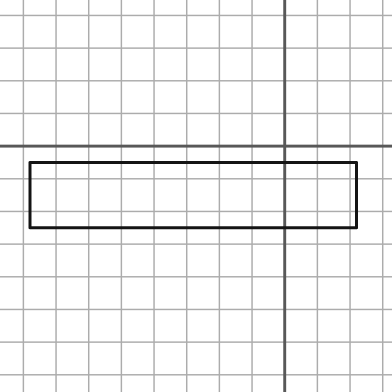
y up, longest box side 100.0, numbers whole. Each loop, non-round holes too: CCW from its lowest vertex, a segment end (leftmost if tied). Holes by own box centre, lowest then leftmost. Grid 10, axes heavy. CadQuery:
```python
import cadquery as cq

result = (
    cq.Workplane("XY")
    .moveTo(-78.0, -25.0)
    .lineTo(22.0, -25.0)
    .lineTo(22.0, -5.0)
    .lineTo(-78.0, -5.0)
    .close()
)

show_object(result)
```